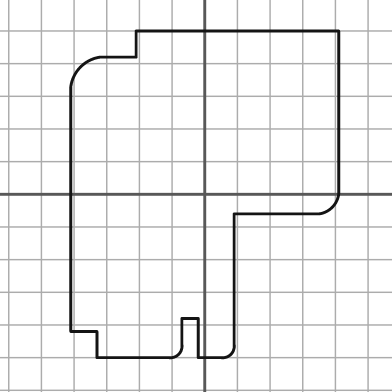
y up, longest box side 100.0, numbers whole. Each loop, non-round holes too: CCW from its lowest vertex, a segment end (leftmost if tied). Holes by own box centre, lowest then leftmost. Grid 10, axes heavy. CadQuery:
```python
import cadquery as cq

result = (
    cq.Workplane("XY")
    .moveTo(-33.0, -50.0)
    .lineTo(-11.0, -50.0)
    .threePointArc((-8.0, -49.0), (-7.0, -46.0))
    .lineTo(-7.0, -38.0)
    .lineTo(-2.0, -38.0)
    .lineTo(-2.0, -50.0)
    .lineTo(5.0, -50.0)
    .threePointArc((8.0, -49.0), (9.0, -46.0))
    .lineTo(9.0, -6.0)
    .lineTo(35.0, -6.0)
    .threePointArc((39.0, -4.0), (41.0, 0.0))
    .lineTo(41.0, 50.0)
    .lineTo(-21.0, 50.0)
    .lineTo(-21.0, 42.0)
    .lineTo(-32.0, 42.0)
    .threePointArc((-38.0, 39.0), (-41.0, 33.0))
    .lineTo(-41.0, -42.0)
    .lineTo(-33.0, -42.0)
    .close()
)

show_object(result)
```